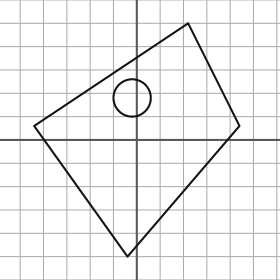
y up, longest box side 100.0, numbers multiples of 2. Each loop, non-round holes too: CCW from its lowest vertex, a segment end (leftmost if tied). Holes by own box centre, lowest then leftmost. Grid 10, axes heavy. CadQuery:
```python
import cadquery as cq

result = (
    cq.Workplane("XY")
    .moveTo(-4.0, -50.0)
    .lineTo(44.0, 6.0)
    .lineTo(22.0, 50.0)
    .lineTo(-44.0, 6.0)
    .close()
    .moveTo(-2.0, 18.0)
    .circle(8.0)
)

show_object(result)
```